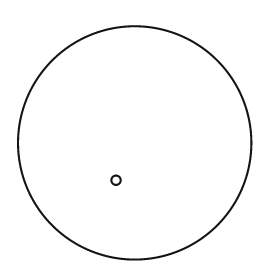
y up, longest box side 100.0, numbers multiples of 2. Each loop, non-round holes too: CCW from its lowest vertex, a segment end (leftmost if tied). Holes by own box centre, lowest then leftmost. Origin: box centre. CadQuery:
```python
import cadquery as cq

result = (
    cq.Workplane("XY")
    .moveTo(0.0, 0.0)
    .circle(50.0)
    .moveTo(-8.0, -16.0)
    .circle(2.0)
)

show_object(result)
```